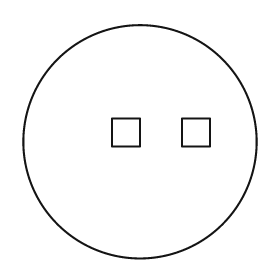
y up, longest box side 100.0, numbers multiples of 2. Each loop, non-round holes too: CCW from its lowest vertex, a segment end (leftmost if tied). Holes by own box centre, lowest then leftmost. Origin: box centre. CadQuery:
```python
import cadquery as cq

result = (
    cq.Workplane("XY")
    .moveTo(0.0, 0.0)
    .circle(50.0)
    .moveTo(-12.0, -2.0)
    .lineTo(0.0, -2.0)
    .lineTo(0.0, 10.0)
    .lineTo(-12.0, 10.0)
    .close()
    .moveTo(18.0, -2.0)
    .lineTo(30.0, -2.0)
    .lineTo(30.0, 10.0)
    .lineTo(18.0, 10.0)
    .close()
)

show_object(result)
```